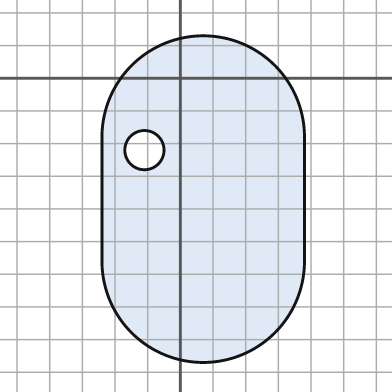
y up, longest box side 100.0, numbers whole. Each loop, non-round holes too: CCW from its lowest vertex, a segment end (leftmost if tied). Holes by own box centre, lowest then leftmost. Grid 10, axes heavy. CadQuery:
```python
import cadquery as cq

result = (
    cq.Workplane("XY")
    .moveTo(-24.0, -56.0)
    .threePointArc((7.0, -87.0), (38.0, -56.0))
    .lineTo(38.0, -18.0)
    .threePointArc((7.0, 13.0), (-24.0, -18.0))
    .close()
    .moveTo(-11.0, -22.0)
    .circle(6.0)
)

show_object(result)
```